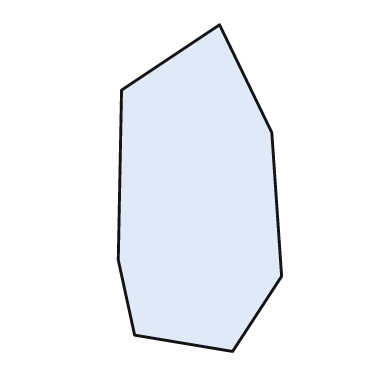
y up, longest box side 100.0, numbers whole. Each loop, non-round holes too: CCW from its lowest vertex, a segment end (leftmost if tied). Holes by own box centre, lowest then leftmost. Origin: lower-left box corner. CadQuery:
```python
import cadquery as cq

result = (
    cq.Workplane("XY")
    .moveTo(35.0, 0.0)
    .lineTo(50.0, 23.0)
    .lineTo(47.0, 67.0)
    .lineTo(31.0, 100.0)
    .lineTo(1.0, 80.0)
    .lineTo(0.0, 28.0)
    .lineTo(5.0, 5.0)
    .close()
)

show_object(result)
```